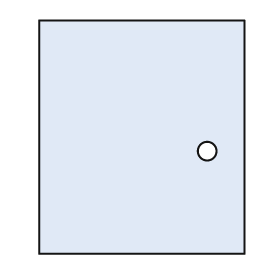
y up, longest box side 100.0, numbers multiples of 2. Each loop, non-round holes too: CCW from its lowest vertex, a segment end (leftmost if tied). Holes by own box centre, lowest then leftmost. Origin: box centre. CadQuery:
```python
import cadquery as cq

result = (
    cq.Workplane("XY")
    .moveTo(-44.0, -50.0)
    .lineTo(44.0, -50.0)
    .lineTo(44.0, 50.0)
    .lineTo(-44.0, 50.0)
    .close()
    .moveTo(28.0, -6.0)
    .circle(4.0)
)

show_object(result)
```